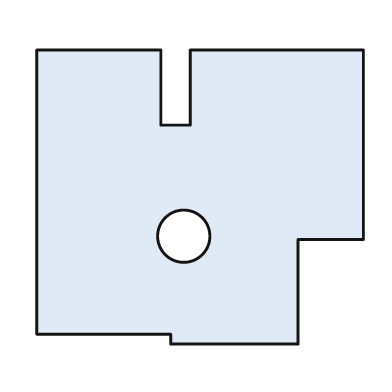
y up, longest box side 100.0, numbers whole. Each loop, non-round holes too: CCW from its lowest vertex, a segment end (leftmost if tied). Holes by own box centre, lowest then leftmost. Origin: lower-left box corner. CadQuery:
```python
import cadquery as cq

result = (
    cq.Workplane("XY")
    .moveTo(41.0, 0.0)
    .lineTo(80.0, 0.0)
    .lineTo(80.0, 32.0)
    .lineTo(100.0, 32.0)
    .lineTo(100.0, 90.0)
    .lineTo(47.0, 90.0)
    .lineTo(47.0, 67.0)
    .lineTo(38.0, 67.0)
    .lineTo(38.0, 90.0)
    .lineTo(0.0, 90.0)
    .lineTo(0.0, 3.0)
    .lineTo(41.0, 3.0)
    .close()
    .moveTo(45.0, 33.0)
    .circle(8.0)
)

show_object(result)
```